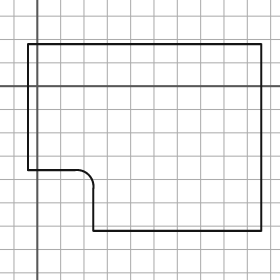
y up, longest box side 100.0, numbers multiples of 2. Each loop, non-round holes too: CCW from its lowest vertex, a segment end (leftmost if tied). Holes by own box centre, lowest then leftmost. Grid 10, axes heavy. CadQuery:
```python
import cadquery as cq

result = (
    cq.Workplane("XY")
    .moveTo(24.0, -62.0)
    .lineTo(96.0, -62.0)
    .lineTo(96.0, 18.0)
    .lineTo(-4.0, 18.0)
    .lineTo(-4.0, -36.0)
    .lineTo(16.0, -36.0)
    .threePointArc((22.0, -38.0), (24.0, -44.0))
    .close()
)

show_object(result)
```